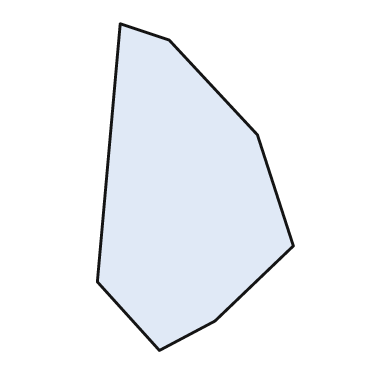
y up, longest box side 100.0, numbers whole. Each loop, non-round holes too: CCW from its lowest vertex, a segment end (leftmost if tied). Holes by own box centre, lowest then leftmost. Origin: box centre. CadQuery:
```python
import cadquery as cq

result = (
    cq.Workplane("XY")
    .moveTo(-11.0, -50.0)
    .lineTo(6.0, -41.0)
    .lineTo(30.0, -18.0)
    .lineTo(19.0, 16.0)
    .lineTo(-8.0, 45.0)
    .lineTo(-23.0, 50.0)
    .lineTo(-30.0, -29.0)
    .close()
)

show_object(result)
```